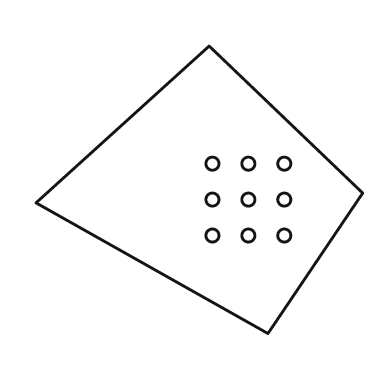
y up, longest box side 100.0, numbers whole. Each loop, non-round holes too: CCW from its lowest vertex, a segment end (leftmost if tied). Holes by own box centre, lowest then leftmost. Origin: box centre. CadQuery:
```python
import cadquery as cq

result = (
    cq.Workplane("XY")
    .moveTo(21.0, -44.0)
    .lineTo(50.0, -1.0)
    .lineTo(3.0, 44.0)
    .lineTo(-50.0, -4.0)
    .close()
    .moveTo(4.0, -14.0)
    .circle(2.0)
    .moveTo(15.0, -14.0)
    .circle(2.0)
    .moveTo(26.0, -14.0)
    .circle(2.0)
    .moveTo(4.0, -3.0)
    .circle(2.0)
    .moveTo(15.0, -3.0)
    .circle(2.0)
    .moveTo(26.0, -3.0)
    .circle(2.0)
    .moveTo(4.0, 8.0)
    .circle(2.0)
    .moveTo(15.0, 8.0)
    .circle(2.0)
    .moveTo(26.0, 8.0)
    .circle(2.0)
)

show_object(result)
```